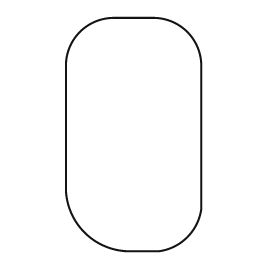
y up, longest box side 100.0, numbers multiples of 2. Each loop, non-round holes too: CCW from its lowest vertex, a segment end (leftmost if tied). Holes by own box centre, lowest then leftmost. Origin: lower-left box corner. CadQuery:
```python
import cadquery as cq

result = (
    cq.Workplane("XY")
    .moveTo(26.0, 0.0)
    .lineTo(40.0, 0.0)
    .threePointArc((52.0, 6.0), (58.0, 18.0))
    .lineTo(58.0, 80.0)
    .threePointArc((52.0, 94.0), (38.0, 100.0))
    .lineTo(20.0, 100.0)
    .threePointArc((6.0, 94.0), (0.0, 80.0))
    .lineTo(0.0, 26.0)
    .threePointArc((8.0, 8.0), (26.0, 0.0))
    .close()
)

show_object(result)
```